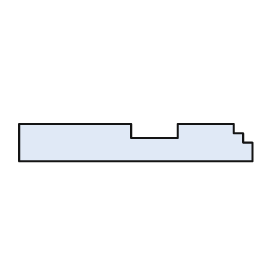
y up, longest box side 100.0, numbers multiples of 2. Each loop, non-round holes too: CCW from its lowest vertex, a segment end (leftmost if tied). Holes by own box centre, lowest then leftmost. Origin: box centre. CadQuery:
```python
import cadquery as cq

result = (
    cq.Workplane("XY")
    .moveTo(-50.0, -8.0)
    .lineTo(50.0, -8.0)
    .lineTo(50.0, 0.0)
    .lineTo(46.0, 0.0)
    .lineTo(46.0, 4.0)
    .lineTo(42.0, 4.0)
    .lineTo(42.0, 8.0)
    .lineTo(18.0, 8.0)
    .lineTo(18.0, 2.0)
    .lineTo(-2.0, 2.0)
    .lineTo(-2.0, 8.0)
    .lineTo(-50.0, 8.0)
    .close()
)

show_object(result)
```